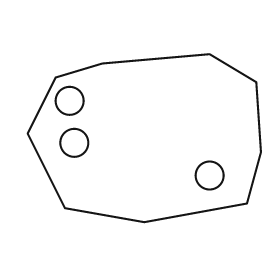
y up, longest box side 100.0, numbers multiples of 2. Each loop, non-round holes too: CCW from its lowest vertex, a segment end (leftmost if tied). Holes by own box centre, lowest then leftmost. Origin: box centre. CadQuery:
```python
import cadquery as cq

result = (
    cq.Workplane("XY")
    .moveTo(0.0, -36.0)
    .lineTo(44.0, -28.0)
    .lineTo(50.0, -6.0)
    .lineTo(48.0, 24.0)
    .lineTo(28.0, 36.0)
    .lineTo(-18.0, 32.0)
    .lineTo(-38.0, 26.0)
    .lineTo(-50.0, 2.0)
    .lineTo(-34.0, -30.0)
    .close()
    .moveTo(28.0, -16.0)
    .circle(6.0)
    .moveTo(-30.0, -2.0)
    .circle(6.0)
    .moveTo(-32.0, 16.0)
    .circle(6.0)
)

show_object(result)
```